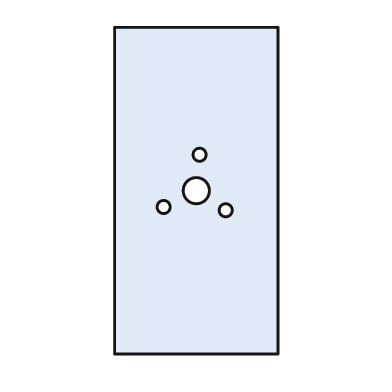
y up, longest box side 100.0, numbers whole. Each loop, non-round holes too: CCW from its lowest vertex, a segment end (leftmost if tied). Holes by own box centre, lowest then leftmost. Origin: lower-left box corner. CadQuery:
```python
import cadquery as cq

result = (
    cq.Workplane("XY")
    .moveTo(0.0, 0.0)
    .lineTo(50.0, 0.0)
    .lineTo(50.0, 100.0)
    .lineTo(0.0, 100.0)
    .close()
    .moveTo(34.0, 44.0)
    .circle(2.0)
    .moveTo(15.0, 45.0)
    .circle(2.0)
    .moveTo(25.0, 50.0)
    .circle(4.0)
    .moveTo(26.0, 61.0)
    .circle(2.0)
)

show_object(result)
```